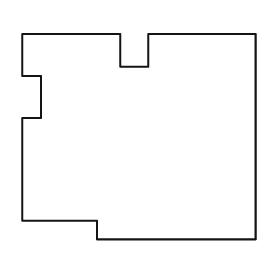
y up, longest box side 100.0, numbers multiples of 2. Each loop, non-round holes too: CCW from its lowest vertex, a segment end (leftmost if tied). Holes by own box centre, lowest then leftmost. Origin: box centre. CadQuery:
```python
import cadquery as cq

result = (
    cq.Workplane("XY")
    .moveTo(-18.0, -44.0)
    .lineTo(50.0, -44.0)
    .lineTo(50.0, 44.0)
    .lineTo(4.0, 44.0)
    .lineTo(4.0, 30.0)
    .lineTo(-8.0, 30.0)
    .lineTo(-8.0, 44.0)
    .lineTo(-50.0, 44.0)
    .lineTo(-50.0, 26.0)
    .lineTo(-42.0, 26.0)
    .lineTo(-42.0, 8.0)
    .lineTo(-50.0, 8.0)
    .lineTo(-50.0, -36.0)
    .lineTo(-18.0, -36.0)
    .close()
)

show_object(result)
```